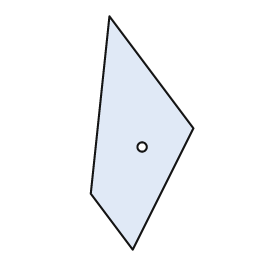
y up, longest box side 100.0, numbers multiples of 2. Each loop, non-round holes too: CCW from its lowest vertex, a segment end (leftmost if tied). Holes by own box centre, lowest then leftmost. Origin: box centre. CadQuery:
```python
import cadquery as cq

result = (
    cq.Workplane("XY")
    .moveTo(-4.0, -50.0)
    .lineTo(22.0, 2.0)
    .lineTo(-14.0, 50.0)
    .lineTo(-22.0, -26.0)
    .close()
    .moveTo(0.0, -6.0)
    .circle(2.0)
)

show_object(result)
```